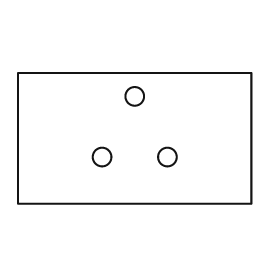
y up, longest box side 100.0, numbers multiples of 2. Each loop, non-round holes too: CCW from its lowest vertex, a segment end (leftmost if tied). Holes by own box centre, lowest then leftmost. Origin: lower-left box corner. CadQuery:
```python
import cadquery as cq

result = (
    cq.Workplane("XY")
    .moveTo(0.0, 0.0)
    .lineTo(100.0, 0.0)
    .lineTo(100.0, 56.0)
    .lineTo(0.0, 56.0)
    .close()
    .moveTo(36.0, 20.0)
    .circle(4.0)
    .moveTo(64.0, 20.0)
    .circle(4.0)
    .moveTo(50.0, 46.0)
    .circle(4.0)
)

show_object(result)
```